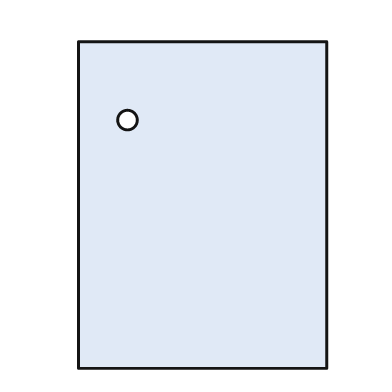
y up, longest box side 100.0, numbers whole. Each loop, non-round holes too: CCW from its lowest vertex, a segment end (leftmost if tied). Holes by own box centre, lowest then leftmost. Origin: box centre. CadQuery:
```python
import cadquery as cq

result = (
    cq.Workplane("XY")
    .moveTo(-38.0, -50.0)
    .lineTo(38.0, -50.0)
    .lineTo(38.0, 50.0)
    .lineTo(-38.0, 50.0)
    .close()
    .moveTo(-23.0, 26.0)
    .circle(3.0)
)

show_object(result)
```